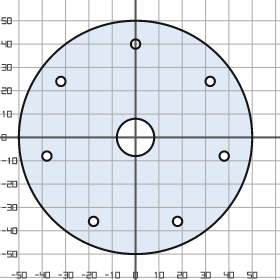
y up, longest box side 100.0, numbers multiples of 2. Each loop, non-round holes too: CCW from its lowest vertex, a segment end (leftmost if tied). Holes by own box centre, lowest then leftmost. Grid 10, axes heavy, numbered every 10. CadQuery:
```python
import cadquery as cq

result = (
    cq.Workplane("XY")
    .moveTo(0.0, 0.0)
    .circle(50.0)
    .moveTo(-18.0, -36.0)
    .circle(2.0)
    .moveTo(18.0, -36.0)
    .circle(2.0)
    .moveTo(-38.0, -8.0)
    .circle(2.0)
    .moveTo(38.0, -8.0)
    .circle(2.0)
    .moveTo(0.0, 0.0)
    .circle(8.0)
    .moveTo(-32.0, 24.0)
    .circle(2.0)
    .moveTo(32.0, 24.0)
    .circle(2.0)
    .moveTo(0.0, 40.0)
    .circle(2.0)
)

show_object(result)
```